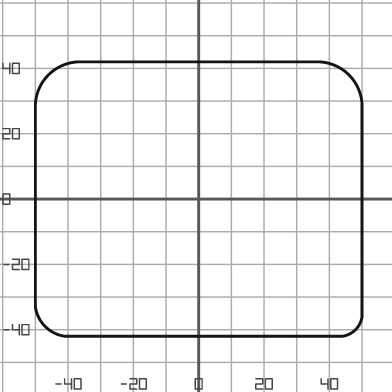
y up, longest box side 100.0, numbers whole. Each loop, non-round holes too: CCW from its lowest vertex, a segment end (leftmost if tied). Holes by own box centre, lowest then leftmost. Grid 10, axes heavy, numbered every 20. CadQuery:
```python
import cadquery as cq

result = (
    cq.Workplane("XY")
    .moveTo(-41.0, -42.0)
    .lineTo(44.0, -42.0)
    .threePointArc((48.0, -40.0), (50.0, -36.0))
    .lineTo(50.0, 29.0)
    .threePointArc((46.0, 38.0), (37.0, 42.0))
    .lineTo(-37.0, 42.0)
    .threePointArc((-46.0, 38.0), (-50.0, 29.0))
    .lineTo(-50.0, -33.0)
    .threePointArc((-47.0, -39.0), (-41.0, -42.0))
    .close()
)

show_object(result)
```